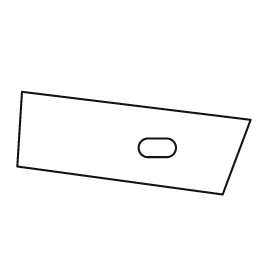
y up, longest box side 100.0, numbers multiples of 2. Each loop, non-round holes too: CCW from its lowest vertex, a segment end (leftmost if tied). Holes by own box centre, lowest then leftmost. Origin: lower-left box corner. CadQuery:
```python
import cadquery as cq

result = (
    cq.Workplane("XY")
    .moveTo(88.0, 0.0)
    .lineTo(100.0, 32.0)
    .lineTo(2.0, 44.0)
    .lineTo(0.0, 12.0)
    .close()
    .moveTo(56.0, 16.0)
    .lineTo(64.0, 16.0)
    .threePointArc((68.0, 20.0), (64.0, 24.0))
    .lineTo(56.0, 24.0)
    .threePointArc((52.0, 20.0), (56.0, 16.0))
    .close()
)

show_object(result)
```